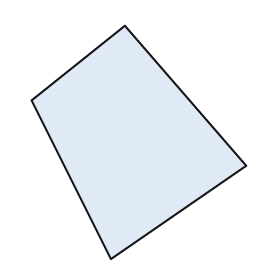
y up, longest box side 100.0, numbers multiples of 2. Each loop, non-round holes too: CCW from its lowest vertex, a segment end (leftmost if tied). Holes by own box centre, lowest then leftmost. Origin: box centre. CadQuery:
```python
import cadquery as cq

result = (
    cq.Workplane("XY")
    .moveTo(-12.0, -50.0)
    .lineTo(46.0, -10.0)
    .lineTo(-6.0, 50.0)
    .lineTo(-46.0, 18.0)
    .close()
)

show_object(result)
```